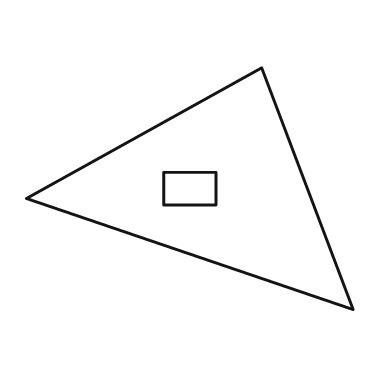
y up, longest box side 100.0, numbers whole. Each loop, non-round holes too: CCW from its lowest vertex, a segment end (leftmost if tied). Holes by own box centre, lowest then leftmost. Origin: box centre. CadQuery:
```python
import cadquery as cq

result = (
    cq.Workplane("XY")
    .moveTo(50.0, -37.0)
    .lineTo(22.0, 37.0)
    .lineTo(-50.0, -3.0)
    .close()
    .moveTo(-8.0, -5.0)
    .lineTo(8.0, -5.0)
    .lineTo(8.0, 5.0)
    .lineTo(-8.0, 5.0)
    .close()
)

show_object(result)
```